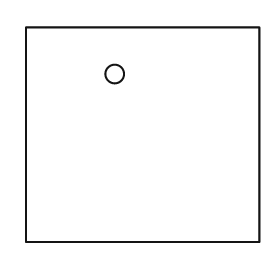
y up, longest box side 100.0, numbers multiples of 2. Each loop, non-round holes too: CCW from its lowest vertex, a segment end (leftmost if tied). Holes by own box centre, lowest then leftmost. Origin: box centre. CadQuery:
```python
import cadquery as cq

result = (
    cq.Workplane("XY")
    .moveTo(-50.0, -46.0)
    .lineTo(50.0, -46.0)
    .lineTo(50.0, 46.0)
    .lineTo(-50.0, 46.0)
    .close()
    .moveTo(-12.0, 26.0)
    .circle(4.0)
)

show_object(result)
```